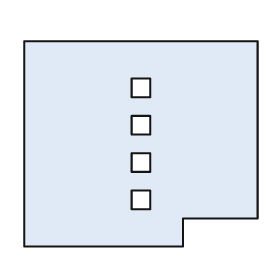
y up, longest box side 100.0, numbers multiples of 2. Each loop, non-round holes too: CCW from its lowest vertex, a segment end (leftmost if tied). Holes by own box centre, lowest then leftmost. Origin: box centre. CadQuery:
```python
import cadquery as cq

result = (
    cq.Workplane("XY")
    .moveTo(-50.0, -44.0)
    .lineTo(18.0, -44.0)
    .lineTo(18.0, -32.0)
    .lineTo(50.0, -32.0)
    .lineTo(50.0, 44.0)
    .lineTo(-50.0, 44.0)
    .close()
    .moveTo(-4.0, -28.0)
    .lineTo(4.0, -28.0)
    .lineTo(4.0, -20.0)
    .lineTo(-4.0, -20.0)
    .close()
    .moveTo(-4.0, -12.0)
    .lineTo(4.0, -12.0)
    .lineTo(4.0, -4.0)
    .lineTo(-4.0, -4.0)
    .close()
    .moveTo(-4.0, 4.0)
    .lineTo(4.0, 4.0)
    .lineTo(4.0, 12.0)
    .lineTo(-4.0, 12.0)
    .close()
    .moveTo(-4.0, 20.0)
    .lineTo(4.0, 20.0)
    .lineTo(4.0, 28.0)
    .lineTo(-4.0, 28.0)
    .close()
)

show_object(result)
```